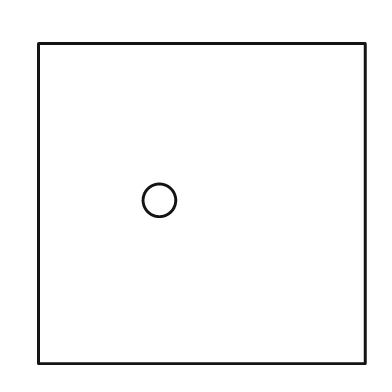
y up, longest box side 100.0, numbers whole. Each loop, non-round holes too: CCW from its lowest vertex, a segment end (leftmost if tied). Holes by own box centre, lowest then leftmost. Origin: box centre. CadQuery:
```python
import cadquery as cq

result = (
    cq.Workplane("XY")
    .moveTo(-50.0, -49.0)
    .lineTo(50.0, -49.0)
    .lineTo(50.0, 49.0)
    .lineTo(-50.0, 49.0)
    .close()
    .moveTo(-13.0, 1.0)
    .circle(5.0)
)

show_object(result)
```